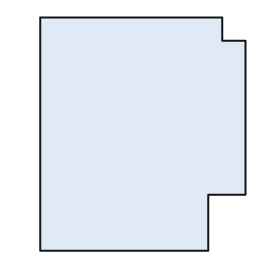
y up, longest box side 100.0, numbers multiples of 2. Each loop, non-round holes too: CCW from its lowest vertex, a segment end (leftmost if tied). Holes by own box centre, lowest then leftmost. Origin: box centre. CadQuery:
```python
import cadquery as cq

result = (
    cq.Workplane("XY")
    .moveTo(-44.0, -50.0)
    .lineTo(28.0, -50.0)
    .lineTo(28.0, -26.0)
    .lineTo(44.0, -26.0)
    .lineTo(44.0, 40.0)
    .lineTo(34.0, 40.0)
    .lineTo(34.0, 50.0)
    .lineTo(-44.0, 50.0)
    .close()
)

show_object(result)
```